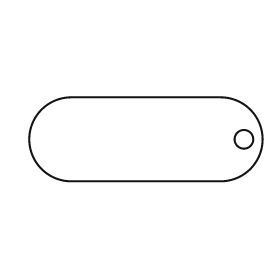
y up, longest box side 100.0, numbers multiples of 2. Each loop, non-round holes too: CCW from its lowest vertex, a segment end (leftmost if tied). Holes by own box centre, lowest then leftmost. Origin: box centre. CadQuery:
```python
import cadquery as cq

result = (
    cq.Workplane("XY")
    .moveTo(-32.0, -18.0)
    .lineTo(32.0, -18.0)
    .threePointArc((50.0, 0.0), (32.0, 18.0))
    .lineTo(-32.0, 18.0)
    .threePointArc((-50.0, 0.0), (-32.0, -18.0))
    .close()
    .moveTo(42.0, 0.0)
    .circle(4.0)
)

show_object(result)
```